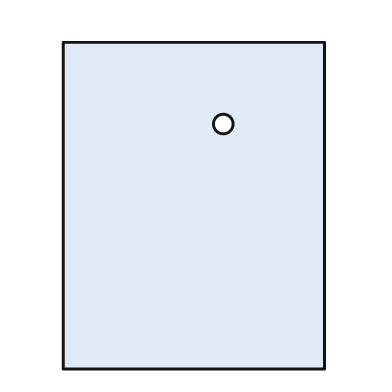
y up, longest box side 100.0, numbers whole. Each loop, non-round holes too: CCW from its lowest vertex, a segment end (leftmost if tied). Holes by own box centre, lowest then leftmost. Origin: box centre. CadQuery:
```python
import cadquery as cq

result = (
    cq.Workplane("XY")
    .moveTo(-40.0, -50.0)
    .lineTo(40.0, -50.0)
    .lineTo(40.0, 50.0)
    .lineTo(-40.0, 50.0)
    .close()
    .moveTo(9.0, 25.0)
    .circle(3.0)
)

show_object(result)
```